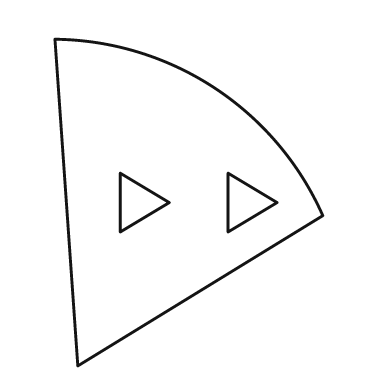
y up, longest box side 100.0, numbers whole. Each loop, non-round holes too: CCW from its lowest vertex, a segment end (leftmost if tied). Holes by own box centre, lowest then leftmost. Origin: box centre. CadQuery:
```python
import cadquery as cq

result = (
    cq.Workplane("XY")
    .moveTo(-34.0, -50.0)
    .lineTo(41.0, -4.0)
    .threePointArc((8.0, 35.0), (-41.0, 50.0))
    .close()
    .moveTo(-21.0, -9.0)
    .lineTo(-6.0, 0.0)
    .lineTo(-21.0, 9.0)
    .close()
    .moveTo(12.0, -9.0)
    .lineTo(27.0, 0.0)
    .lineTo(12.0, 9.0)
    .close()
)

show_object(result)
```